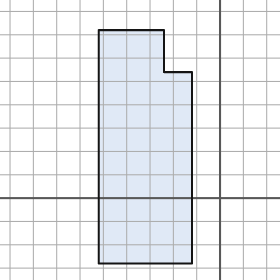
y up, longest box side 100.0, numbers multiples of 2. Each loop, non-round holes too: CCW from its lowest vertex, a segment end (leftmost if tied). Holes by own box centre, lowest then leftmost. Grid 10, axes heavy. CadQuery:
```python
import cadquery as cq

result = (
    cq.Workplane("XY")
    .moveTo(-52.0, -28.0)
    .lineTo(-12.0, -28.0)
    .lineTo(-12.0, 54.0)
    .lineTo(-24.0, 54.0)
    .lineTo(-24.0, 72.0)
    .lineTo(-52.0, 72.0)
    .close()
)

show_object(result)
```